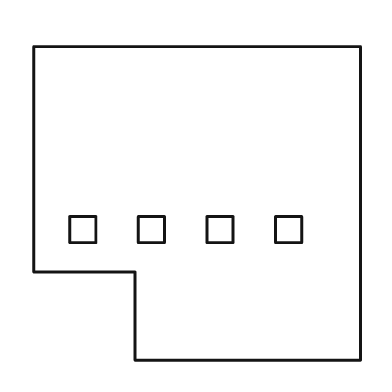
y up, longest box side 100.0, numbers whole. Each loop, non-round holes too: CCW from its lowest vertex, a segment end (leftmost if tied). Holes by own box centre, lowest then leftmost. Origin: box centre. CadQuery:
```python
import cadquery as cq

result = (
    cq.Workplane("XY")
    .moveTo(-19.0, -48.0)
    .lineTo(50.0, -48.0)
    .lineTo(50.0, 48.0)
    .lineTo(-50.0, 48.0)
    .lineTo(-50.0, -21.0)
    .lineTo(-19.0, -21.0)
    .close()
    .moveTo(-39.0, -12.0)
    .lineTo(-31.0, -12.0)
    .lineTo(-31.0, -4.0)
    .lineTo(-39.0, -4.0)
    .close()
    .moveTo(-18.0, -12.0)
    .lineTo(-10.0, -12.0)
    .lineTo(-10.0, -4.0)
    .lineTo(-18.0, -4.0)
    .close()
    .moveTo(3.0, -12.0)
    .lineTo(11.0, -12.0)
    .lineTo(11.0, -4.0)
    .lineTo(3.0, -4.0)
    .close()
    .moveTo(24.0, -12.0)
    .lineTo(32.0, -12.0)
    .lineTo(32.0, -4.0)
    .lineTo(24.0, -4.0)
    .close()
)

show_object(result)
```